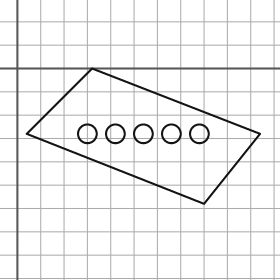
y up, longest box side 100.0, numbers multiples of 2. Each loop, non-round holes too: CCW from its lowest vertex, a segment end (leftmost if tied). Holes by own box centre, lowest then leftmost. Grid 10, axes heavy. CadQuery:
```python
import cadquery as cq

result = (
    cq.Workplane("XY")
    .moveTo(80.0, -58.0)
    .lineTo(104.0, -28.0)
    .lineTo(32.0, 0.0)
    .lineTo(4.0, -28.0)
    .close()
    .moveTo(30.0, -28.0)
    .circle(4.0)
    .moveTo(42.0, -28.0)
    .circle(4.0)
    .moveTo(54.0, -28.0)
    .circle(4.0)
    .moveTo(66.0, -28.0)
    .circle(4.0)
    .moveTo(78.0, -28.0)
    .circle(4.0)
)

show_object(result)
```